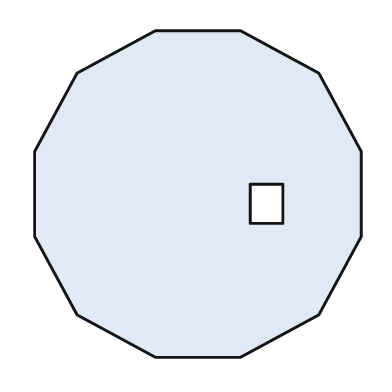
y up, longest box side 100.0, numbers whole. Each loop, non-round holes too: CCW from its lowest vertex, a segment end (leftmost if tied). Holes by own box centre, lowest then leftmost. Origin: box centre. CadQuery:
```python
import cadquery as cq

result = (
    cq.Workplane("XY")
    .moveTo(-13.0, -50.0)
    .lineTo(13.0, -50.0)
    .lineTo(37.0, -37.0)
    .lineTo(50.0, -13.0)
    .lineTo(50.0, 13.0)
    .lineTo(37.0, 37.0)
    .lineTo(13.0, 50.0)
    .lineTo(-13.0, 50.0)
    .lineTo(-37.0, 37.0)
    .lineTo(-50.0, 13.0)
    .lineTo(-50.0, -13.0)
    .lineTo(-37.0, -37.0)
    .close()
    .moveTo(16.0, -9.0)
    .lineTo(26.0, -9.0)
    .lineTo(26.0, 3.0)
    .lineTo(16.0, 3.0)
    .close()
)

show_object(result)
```